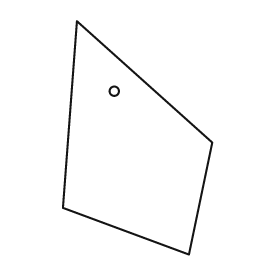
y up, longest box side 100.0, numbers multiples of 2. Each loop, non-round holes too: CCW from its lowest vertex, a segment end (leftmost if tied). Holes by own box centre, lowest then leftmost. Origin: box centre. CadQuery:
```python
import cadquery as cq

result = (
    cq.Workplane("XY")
    .moveTo(22.0, -50.0)
    .lineTo(32.0, -2.0)
    .lineTo(-26.0, 50.0)
    .lineTo(-32.0, -30.0)
    .close()
    .moveTo(-10.0, 20.0)
    .circle(2.0)
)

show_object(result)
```